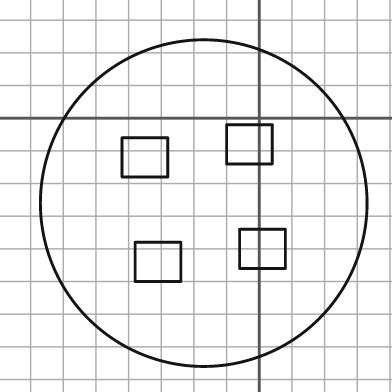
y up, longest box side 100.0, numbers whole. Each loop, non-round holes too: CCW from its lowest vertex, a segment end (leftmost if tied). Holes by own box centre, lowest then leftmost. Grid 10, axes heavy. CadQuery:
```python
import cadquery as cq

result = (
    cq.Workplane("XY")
    .moveTo(-17.0, -26.0)
    .circle(50.0)
    .moveTo(-38.0, -50.0)
    .lineTo(-24.0, -50.0)
    .lineTo(-24.0, -38.0)
    .lineTo(-38.0, -38.0)
    .close()
    .moveTo(-6.0, -46.0)
    .lineTo(8.0, -46.0)
    .lineTo(8.0, -34.0)
    .lineTo(-6.0, -34.0)
    .close()
    .moveTo(-42.0, -18.0)
    .lineTo(-28.0, -18.0)
    .lineTo(-28.0, -6.0)
    .lineTo(-42.0, -6.0)
    .close()
    .moveTo(-10.0, -14.0)
    .lineTo(4.0, -14.0)
    .lineTo(4.0, -2.0)
    .lineTo(-10.0, -2.0)
    .close()
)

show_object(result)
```